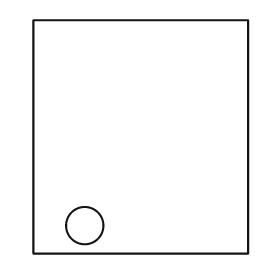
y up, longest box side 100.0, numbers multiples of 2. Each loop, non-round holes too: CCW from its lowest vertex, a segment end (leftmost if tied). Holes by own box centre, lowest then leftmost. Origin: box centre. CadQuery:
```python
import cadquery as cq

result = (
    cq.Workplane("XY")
    .moveTo(-46.0, -50.0)
    .lineTo(46.0, -50.0)
    .lineTo(46.0, 50.0)
    .lineTo(-46.0, 50.0)
    .close()
    .moveTo(-24.0, -38.0)
    .circle(8.0)
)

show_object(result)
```